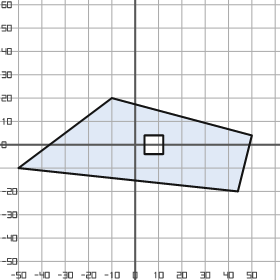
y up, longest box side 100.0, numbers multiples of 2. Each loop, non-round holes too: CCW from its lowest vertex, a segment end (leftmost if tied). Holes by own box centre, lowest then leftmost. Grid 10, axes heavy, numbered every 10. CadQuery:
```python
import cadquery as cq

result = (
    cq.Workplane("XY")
    .moveTo(44.0, -20.0)
    .lineTo(50.0, 4.0)
    .lineTo(-10.0, 20.0)
    .lineTo(-50.0, -10.0)
    .close()
    .moveTo(4.0, -4.0)
    .lineTo(12.0, -4.0)
    .lineTo(12.0, 4.0)
    .lineTo(4.0, 4.0)
    .close()
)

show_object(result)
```